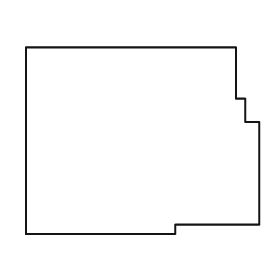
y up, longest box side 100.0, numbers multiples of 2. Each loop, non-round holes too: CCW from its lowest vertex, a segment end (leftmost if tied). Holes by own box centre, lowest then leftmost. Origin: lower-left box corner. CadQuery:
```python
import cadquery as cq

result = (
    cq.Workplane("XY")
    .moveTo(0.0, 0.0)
    .lineTo(64.0, 0.0)
    .lineTo(64.0, 4.0)
    .lineTo(100.0, 4.0)
    .lineTo(100.0, 48.0)
    .lineTo(94.0, 48.0)
    .lineTo(94.0, 58.0)
    .lineTo(90.0, 58.0)
    .lineTo(90.0, 80.0)
    .lineTo(0.0, 80.0)
    .close()
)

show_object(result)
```